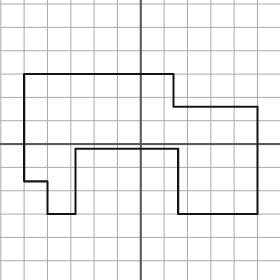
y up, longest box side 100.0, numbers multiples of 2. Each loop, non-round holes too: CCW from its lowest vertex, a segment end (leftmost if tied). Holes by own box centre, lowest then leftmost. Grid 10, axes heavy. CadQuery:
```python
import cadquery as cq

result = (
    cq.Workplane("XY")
    .moveTo(-40.0, -30.0)
    .lineTo(-28.0, -30.0)
    .lineTo(-28.0, -2.0)
    .lineTo(16.0, -2.0)
    .lineTo(16.0, -30.0)
    .lineTo(50.0, -30.0)
    .lineTo(50.0, 16.0)
    .lineTo(14.0, 16.0)
    .lineTo(14.0, 30.0)
    .lineTo(-50.0, 30.0)
    .lineTo(-50.0, -16.0)
    .lineTo(-40.0, -16.0)
    .close()
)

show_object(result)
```